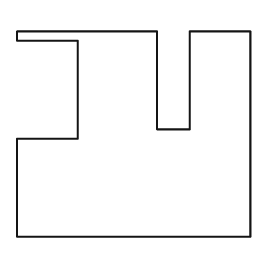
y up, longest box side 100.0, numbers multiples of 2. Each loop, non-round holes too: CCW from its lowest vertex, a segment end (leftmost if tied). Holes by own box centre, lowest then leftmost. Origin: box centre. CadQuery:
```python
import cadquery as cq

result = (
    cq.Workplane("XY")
    .moveTo(-50.0, -44.0)
    .lineTo(50.0, -44.0)
    .lineTo(50.0, 44.0)
    .lineTo(24.0, 44.0)
    .lineTo(24.0, 2.0)
    .lineTo(10.0, 2.0)
    .lineTo(10.0, 44.0)
    .lineTo(-50.0, 44.0)
    .lineTo(-50.0, 40.0)
    .lineTo(-24.0, 40.0)
    .lineTo(-24.0, -2.0)
    .lineTo(-50.0, -2.0)
    .close()
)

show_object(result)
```